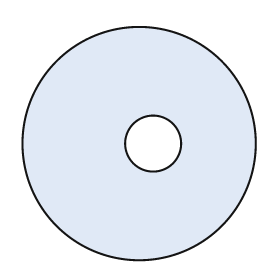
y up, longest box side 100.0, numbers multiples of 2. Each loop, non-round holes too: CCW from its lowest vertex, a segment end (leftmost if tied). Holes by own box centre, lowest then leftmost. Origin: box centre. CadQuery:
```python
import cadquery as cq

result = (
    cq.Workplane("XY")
    .moveTo(0.0, 0.0)
    .circle(50.0)
    .moveTo(6.0, 0.0)
    .circle(12.0)
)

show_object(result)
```